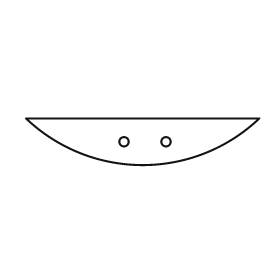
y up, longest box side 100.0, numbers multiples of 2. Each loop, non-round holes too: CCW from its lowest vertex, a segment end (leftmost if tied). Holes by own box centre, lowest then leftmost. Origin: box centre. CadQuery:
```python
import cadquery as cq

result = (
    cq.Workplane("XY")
    .moveTo(-50.0, 10.0)
    .threePointArc((0.0, -10.0), (50.0, 10.0))
    .close()
    .moveTo(-8.0, 0.0)
    .circle(2.0)
    .moveTo(10.0, 0.0)
    .circle(2.0)
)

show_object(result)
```